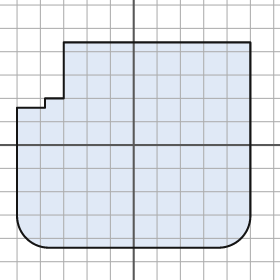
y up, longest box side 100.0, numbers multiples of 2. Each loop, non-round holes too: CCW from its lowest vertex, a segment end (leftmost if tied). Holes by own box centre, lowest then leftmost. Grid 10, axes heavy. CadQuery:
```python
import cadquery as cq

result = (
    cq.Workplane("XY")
    .moveTo(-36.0, -44.0)
    .lineTo(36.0, -44.0)
    .threePointArc((46.0, -40.0), (50.0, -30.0))
    .lineTo(50.0, 44.0)
    .lineTo(-30.0, 44.0)
    .lineTo(-30.0, 20.0)
    .lineTo(-38.0, 20.0)
    .lineTo(-38.0, 16.0)
    .lineTo(-50.0, 16.0)
    .lineTo(-50.0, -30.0)
    .threePointArc((-46.0, -40.0), (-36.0, -44.0))
    .close()
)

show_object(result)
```